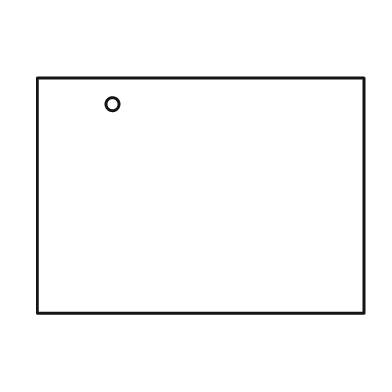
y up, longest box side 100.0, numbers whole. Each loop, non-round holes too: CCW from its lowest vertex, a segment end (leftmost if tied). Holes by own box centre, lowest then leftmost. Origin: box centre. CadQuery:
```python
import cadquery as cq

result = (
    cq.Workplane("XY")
    .moveTo(-50.0, -36.0)
    .lineTo(50.0, -36.0)
    .lineTo(50.0, 36.0)
    .lineTo(-50.0, 36.0)
    .close()
    .moveTo(-27.0, 28.0)
    .circle(2.0)
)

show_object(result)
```